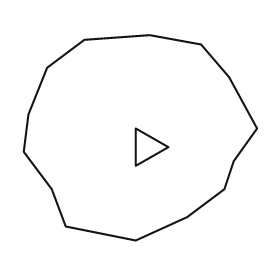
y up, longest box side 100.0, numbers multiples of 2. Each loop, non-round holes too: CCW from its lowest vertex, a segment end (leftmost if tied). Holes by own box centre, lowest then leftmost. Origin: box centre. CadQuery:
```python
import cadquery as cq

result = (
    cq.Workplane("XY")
    .moveTo(-2.0, -44.0)
    .lineTo(20.0, -34.0)
    .lineTo(36.0, -22.0)
    .lineTo(40.0, -10.0)
    .lineTo(50.0, 4.0)
    .lineTo(38.0, 26.0)
    .lineTo(26.0, 40.0)
    .lineTo(4.0, 44.0)
    .lineTo(-24.0, 42.0)
    .lineTo(-40.0, 30.0)
    .lineTo(-48.0, 10.0)
    .lineTo(-50.0, -6.0)
    .lineTo(-38.0, -22.0)
    .lineTo(-32.0, -38.0)
    .close()
    .moveTo(-2.0, -12.0)
    .lineTo(12.0, -4.0)
    .lineTo(-2.0, 4.0)
    .close()
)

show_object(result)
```